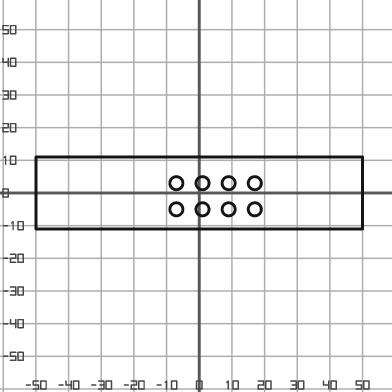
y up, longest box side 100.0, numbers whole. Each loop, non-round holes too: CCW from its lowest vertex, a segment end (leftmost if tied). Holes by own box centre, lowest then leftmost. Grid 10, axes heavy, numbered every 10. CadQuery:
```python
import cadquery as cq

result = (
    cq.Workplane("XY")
    .moveTo(-50.0, -11.0)
    .lineTo(50.0, -11.0)
    .lineTo(50.0, 11.0)
    .lineTo(-50.0, 11.0)
    .close()
    .moveTo(-7.0, -5.0)
    .circle(2.0)
    .moveTo(1.0, -5.0)
    .circle(2.0)
    .moveTo(9.0, -5.0)
    .circle(2.0)
    .moveTo(17.0, -5.0)
    .circle(2.0)
    .moveTo(-7.0, 3.0)
    .circle(2.0)
    .moveTo(1.0, 3.0)
    .circle(2.0)
    .moveTo(9.0, 3.0)
    .circle(2.0)
    .moveTo(17.0, 3.0)
    .circle(2.0)
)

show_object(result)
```